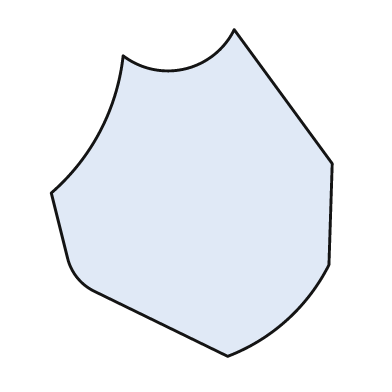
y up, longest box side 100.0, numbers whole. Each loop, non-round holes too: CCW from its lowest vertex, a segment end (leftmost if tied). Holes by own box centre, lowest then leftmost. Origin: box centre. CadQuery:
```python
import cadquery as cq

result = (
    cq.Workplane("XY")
    .moveTo(11.0, -50.0)
    .threePointArc((29.0, -39.0), (42.0, -22.0))
    .lineTo(43.0, 9.0)
    .lineTo(13.0, 50.0)
    .threePointArc((-2.0, 38.0), (-21.0, 42.0))
    .threePointArc((-28.0, 19.0), (-43.0, 0.0))
    .lineTo(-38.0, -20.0)
    .threePointArc((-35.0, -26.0), (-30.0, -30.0))
    .close()
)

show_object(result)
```